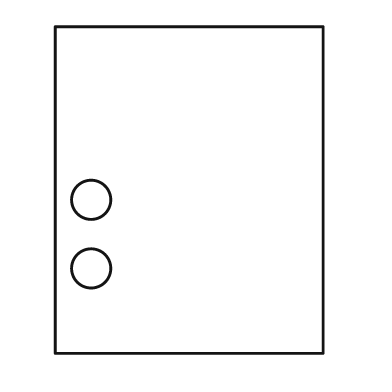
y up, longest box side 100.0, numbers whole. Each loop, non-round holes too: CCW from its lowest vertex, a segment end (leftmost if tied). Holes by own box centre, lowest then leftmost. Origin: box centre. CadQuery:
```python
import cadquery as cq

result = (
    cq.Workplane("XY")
    .moveTo(-41.0, -50.0)
    .lineTo(41.0, -50.0)
    .lineTo(41.0, 50.0)
    .lineTo(-41.0, 50.0)
    .close()
    .moveTo(-30.0, -24.0)
    .circle(6.0)
    .moveTo(-30.0, -3.0)
    .circle(6.0)
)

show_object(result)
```